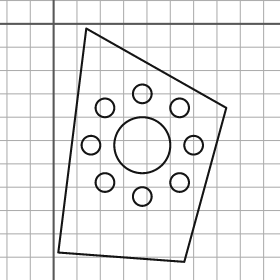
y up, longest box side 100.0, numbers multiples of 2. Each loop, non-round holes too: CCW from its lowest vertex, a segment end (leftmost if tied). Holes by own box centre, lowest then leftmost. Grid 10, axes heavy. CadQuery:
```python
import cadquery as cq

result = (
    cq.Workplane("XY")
    .moveTo(56.0, -102.0)
    .lineTo(74.0, -36.0)
    .lineTo(14.0, -2.0)
    .lineTo(2.0, -98.0)
    .close()
    .moveTo(38.0, -74.0)
    .circle(4.0)
    .moveTo(22.0, -68.0)
    .circle(4.0)
    .moveTo(54.0, -68.0)
    .circle(4.0)
    .moveTo(16.0, -52.0)
    .circle(4.0)
    .moveTo(38.0, -52.0)
    .circle(12.0)
    .moveTo(60.0, -52.0)
    .circle(4.0)
    .moveTo(22.0, -36.0)
    .circle(4.0)
    .moveTo(54.0, -36.0)
    .circle(4.0)
    .moveTo(38.0, -30.0)
    .circle(4.0)
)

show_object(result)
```